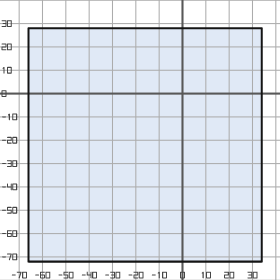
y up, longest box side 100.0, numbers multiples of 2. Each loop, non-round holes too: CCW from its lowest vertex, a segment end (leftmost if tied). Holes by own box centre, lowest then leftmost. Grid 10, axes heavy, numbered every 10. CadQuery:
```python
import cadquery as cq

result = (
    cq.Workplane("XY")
    .moveTo(-66.0, -72.0)
    .lineTo(34.0, -72.0)
    .lineTo(34.0, 28.0)
    .lineTo(-66.0, 28.0)
    .close()
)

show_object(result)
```